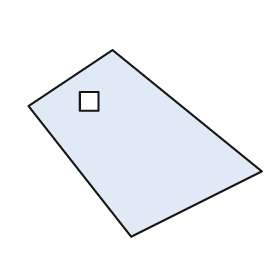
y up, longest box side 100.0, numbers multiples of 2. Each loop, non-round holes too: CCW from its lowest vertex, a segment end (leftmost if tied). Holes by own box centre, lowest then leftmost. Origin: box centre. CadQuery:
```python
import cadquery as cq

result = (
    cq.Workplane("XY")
    .moveTo(-6.0, -40.0)
    .lineTo(50.0, -12.0)
    .lineTo(-14.0, 40.0)
    .lineTo(-50.0, 16.0)
    .close()
    .moveTo(-28.0, 14.0)
    .lineTo(-20.0, 14.0)
    .lineTo(-20.0, 22.0)
    .lineTo(-28.0, 22.0)
    .close()
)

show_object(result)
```